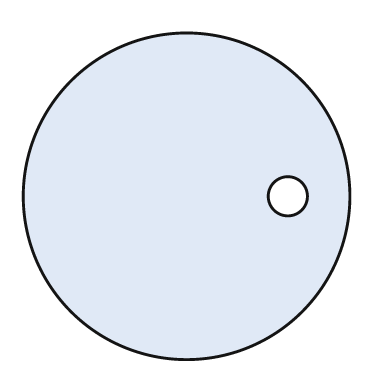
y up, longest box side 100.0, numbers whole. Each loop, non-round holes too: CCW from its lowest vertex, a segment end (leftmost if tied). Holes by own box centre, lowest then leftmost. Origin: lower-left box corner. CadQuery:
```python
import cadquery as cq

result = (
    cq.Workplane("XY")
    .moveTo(50.0, 50.0)
    .circle(50.0)
    .moveTo(81.0, 50.0)
    .circle(6.0)
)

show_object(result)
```